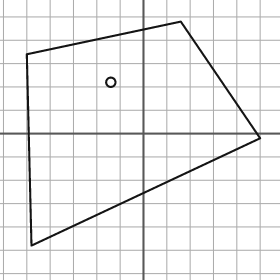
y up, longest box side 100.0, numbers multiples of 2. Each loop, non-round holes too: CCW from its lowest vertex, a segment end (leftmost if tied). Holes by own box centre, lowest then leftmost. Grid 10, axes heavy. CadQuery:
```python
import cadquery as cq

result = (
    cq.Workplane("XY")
    .moveTo(-48.0, -48.0)
    .lineTo(50.0, -2.0)
    .lineTo(16.0, 48.0)
    .lineTo(-50.0, 34.0)
    .close()
    .moveTo(-14.0, 22.0)
    .circle(2.0)
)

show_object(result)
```